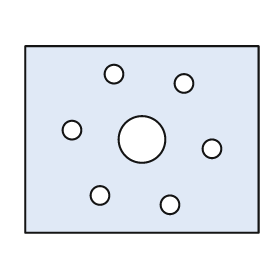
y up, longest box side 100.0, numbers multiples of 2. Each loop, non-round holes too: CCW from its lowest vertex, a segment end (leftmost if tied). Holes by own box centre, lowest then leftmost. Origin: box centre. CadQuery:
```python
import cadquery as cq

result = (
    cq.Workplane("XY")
    .moveTo(-50.0, -40.0)
    .lineTo(50.0, -40.0)
    .lineTo(50.0, 40.0)
    .lineTo(-50.0, 40.0)
    .close()
    .moveTo(12.0, -28.0)
    .circle(4.0)
    .moveTo(-18.0, -24.0)
    .circle(4.0)
    .moveTo(30.0, -4.0)
    .circle(4.0)
    .moveTo(0.0, 0.0)
    .circle(10.0)
    .moveTo(-30.0, 4.0)
    .circle(4.0)
    .moveTo(18.0, 24.0)
    .circle(4.0)
    .moveTo(-12.0, 28.0)
    .circle(4.0)
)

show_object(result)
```